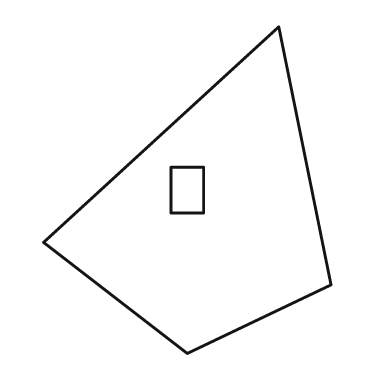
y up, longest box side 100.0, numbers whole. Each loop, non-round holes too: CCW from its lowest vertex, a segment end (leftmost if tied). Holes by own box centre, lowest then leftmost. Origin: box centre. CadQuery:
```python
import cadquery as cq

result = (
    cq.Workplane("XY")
    .moveTo(0.0, -50.0)
    .lineTo(44.0, -29.0)
    .lineTo(28.0, 50.0)
    .lineTo(-44.0, -16.0)
    .close()
    .moveTo(-5.0, -7.0)
    .lineTo(5.0, -7.0)
    .lineTo(5.0, 7.0)
    .lineTo(-5.0, 7.0)
    .close()
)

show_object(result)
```